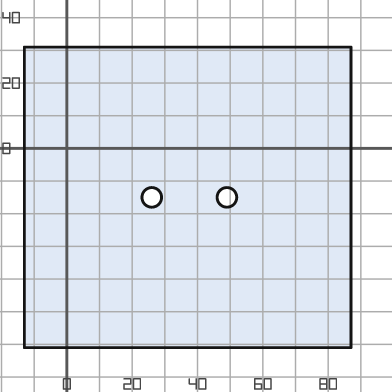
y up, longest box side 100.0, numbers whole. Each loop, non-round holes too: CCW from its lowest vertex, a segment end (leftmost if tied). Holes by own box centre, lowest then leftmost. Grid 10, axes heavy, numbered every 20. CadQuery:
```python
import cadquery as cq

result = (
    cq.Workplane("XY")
    .moveTo(-13.0, -61.0)
    .lineTo(87.0, -61.0)
    .lineTo(87.0, 31.0)
    .lineTo(-13.0, 31.0)
    .close()
    .moveTo(26.0, -15.0)
    .circle(3.0)
    .moveTo(49.0, -15.0)
    .circle(3.0)
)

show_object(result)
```